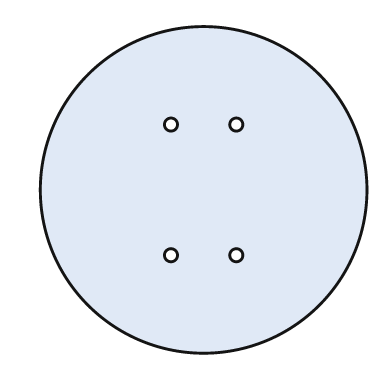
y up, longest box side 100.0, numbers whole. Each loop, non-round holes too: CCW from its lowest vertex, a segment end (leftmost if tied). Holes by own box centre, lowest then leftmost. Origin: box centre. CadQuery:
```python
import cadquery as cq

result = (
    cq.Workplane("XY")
    .moveTo(0.0, 0.0)
    .circle(50.0)
    .moveTo(-10.0, -20.0)
    .circle(2.0)
    .moveTo(10.0, -20.0)
    .circle(2.0)
    .moveTo(-10.0, 20.0)
    .circle(2.0)
    .moveTo(10.0, 20.0)
    .circle(2.0)
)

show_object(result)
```